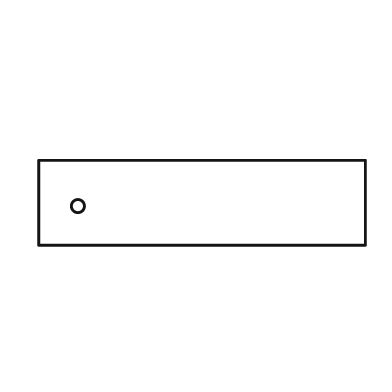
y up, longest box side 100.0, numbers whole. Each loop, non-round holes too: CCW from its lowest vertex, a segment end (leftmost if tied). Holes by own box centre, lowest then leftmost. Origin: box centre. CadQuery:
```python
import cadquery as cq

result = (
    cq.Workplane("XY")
    .moveTo(-50.0, -13.0)
    .lineTo(50.0, -13.0)
    .lineTo(50.0, 13.0)
    .lineTo(-50.0, 13.0)
    .close()
    .moveTo(-38.0, -1.0)
    .circle(2.0)
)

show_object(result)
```